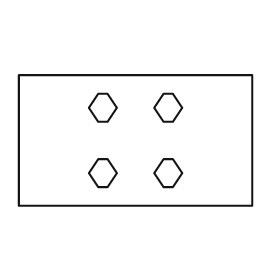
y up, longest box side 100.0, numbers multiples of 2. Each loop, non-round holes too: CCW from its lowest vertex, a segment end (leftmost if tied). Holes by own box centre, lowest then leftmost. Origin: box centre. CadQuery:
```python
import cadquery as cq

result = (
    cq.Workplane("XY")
    .moveTo(-50.0, -28.0)
    .lineTo(50.0, -28.0)
    .lineTo(50.0, 28.0)
    .lineTo(-50.0, 28.0)
    .close()
    .moveTo(-16.0, -20.0)
    .lineTo(-12.0, -20.0)
    .lineTo(-8.0, -14.0)
    .lineTo(-12.0, -8.0)
    .lineTo(-16.0, -8.0)
    .lineTo(-20.0, -14.0)
    .close()
    .moveTo(12.0, -20.0)
    .lineTo(16.0, -20.0)
    .lineTo(20.0, -14.0)
    .lineTo(16.0, -8.0)
    .lineTo(12.0, -8.0)
    .lineTo(8.0, -14.0)
    .close()
    .moveTo(-16.0, 8.0)
    .lineTo(-12.0, 8.0)
    .lineTo(-8.0, 14.0)
    .lineTo(-12.0, 20.0)
    .lineTo(-16.0, 20.0)
    .lineTo(-20.0, 14.0)
    .close()
    .moveTo(12.0, 8.0)
    .lineTo(16.0, 8.0)
    .lineTo(20.0, 14.0)
    .lineTo(16.0, 20.0)
    .lineTo(12.0, 20.0)
    .lineTo(8.0, 14.0)
    .close()
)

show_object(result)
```